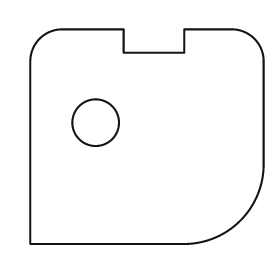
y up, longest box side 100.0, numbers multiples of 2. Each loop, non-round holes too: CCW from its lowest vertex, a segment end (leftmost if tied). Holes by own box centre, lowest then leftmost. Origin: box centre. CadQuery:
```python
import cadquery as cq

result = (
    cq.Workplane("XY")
    .moveTo(-50.0, -46.0)
    .lineTo(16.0, -46.0)
    .threePointArc((40.0, -36.0), (50.0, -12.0))
    .lineTo(50.0, 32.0)
    .threePointArc((46.0, 42.0), (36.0, 46.0))
    .lineTo(16.0, 46.0)
    .lineTo(16.0, 36.0)
    .lineTo(-10.0, 36.0)
    .lineTo(-10.0, 46.0)
    .lineTo(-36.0, 46.0)
    .threePointArc((-46.0, 42.0), (-50.0, 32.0))
    .close()
    .moveTo(-22.0, 6.0)
    .circle(10.0)
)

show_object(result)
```